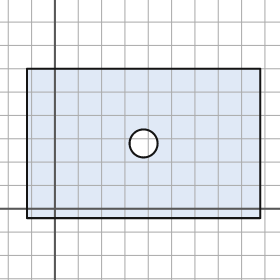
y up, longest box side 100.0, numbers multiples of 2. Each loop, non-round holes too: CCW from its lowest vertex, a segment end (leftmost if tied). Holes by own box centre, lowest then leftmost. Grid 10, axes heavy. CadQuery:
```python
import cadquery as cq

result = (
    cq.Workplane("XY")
    .moveTo(-12.0, -4.0)
    .lineTo(88.0, -4.0)
    .lineTo(88.0, 60.0)
    .lineTo(-12.0, 60.0)
    .close()
    .moveTo(38.0, 28.0)
    .circle(6.0)
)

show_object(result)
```